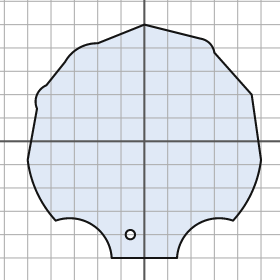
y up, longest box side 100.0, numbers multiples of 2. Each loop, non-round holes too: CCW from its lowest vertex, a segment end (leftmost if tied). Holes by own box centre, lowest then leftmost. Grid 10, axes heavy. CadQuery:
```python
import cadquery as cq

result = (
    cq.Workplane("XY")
    .moveTo(-14.0, -50.0)
    .lineTo(14.0, -50.0)
    .threePointArc((22.0, -36.0), (38.0, -34.0))
    .threePointArc((46.0, -22.0), (50.0, -8.0))
    .lineTo(46.0, 20.0)
    .lineTo(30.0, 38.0)
    .threePointArc((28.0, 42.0), (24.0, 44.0))
    .lineTo(0.0, 50.0)
    .lineTo(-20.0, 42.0)
    .threePointArc((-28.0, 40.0), (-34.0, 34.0))
    .lineTo(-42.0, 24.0)
    .threePointArc((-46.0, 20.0), (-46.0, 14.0))
    .lineTo(-50.0, -8.0)
    .threePointArc((-46.0, -22.0), (-38.0, -34.0))
    .threePointArc((-22.0, -36.0), (-14.0, -50.0))
    .close()
    .moveTo(-6.0, -40.0)
    .circle(2.0)
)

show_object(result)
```